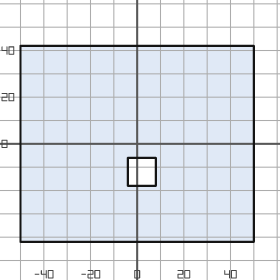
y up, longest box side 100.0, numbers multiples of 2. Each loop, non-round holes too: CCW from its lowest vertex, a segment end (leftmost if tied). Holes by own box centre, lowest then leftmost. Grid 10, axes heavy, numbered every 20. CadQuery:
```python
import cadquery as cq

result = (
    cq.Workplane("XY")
    .moveTo(-50.0, -42.0)
    .lineTo(50.0, -42.0)
    .lineTo(50.0, 42.0)
    .lineTo(-50.0, 42.0)
    .close()
    .moveTo(-4.0, -18.0)
    .lineTo(8.0, -18.0)
    .lineTo(8.0, -6.0)
    .lineTo(-4.0, -6.0)
    .close()
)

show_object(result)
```